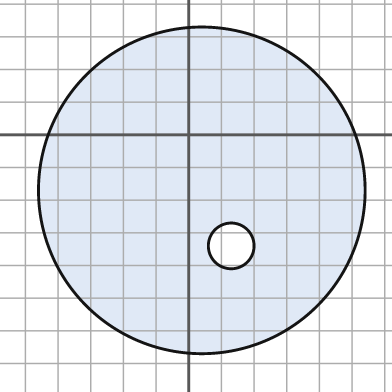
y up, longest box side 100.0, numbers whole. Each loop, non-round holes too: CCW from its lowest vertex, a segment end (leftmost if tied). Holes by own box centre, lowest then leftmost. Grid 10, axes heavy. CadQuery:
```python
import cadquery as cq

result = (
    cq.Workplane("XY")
    .moveTo(4.0, -17.0)
    .circle(50.0)
    .moveTo(13.0, -34.0)
    .circle(7.0)
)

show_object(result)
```